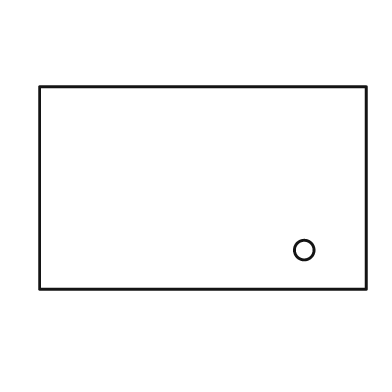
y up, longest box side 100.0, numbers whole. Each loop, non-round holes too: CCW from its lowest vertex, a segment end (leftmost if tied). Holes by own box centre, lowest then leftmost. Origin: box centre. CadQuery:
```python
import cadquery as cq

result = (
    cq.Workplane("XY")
    .moveTo(-50.0, -31.0)
    .lineTo(50.0, -31.0)
    .lineTo(50.0, 31.0)
    .lineTo(-50.0, 31.0)
    .close()
    .moveTo(31.0, -19.0)
    .circle(3.0)
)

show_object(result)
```